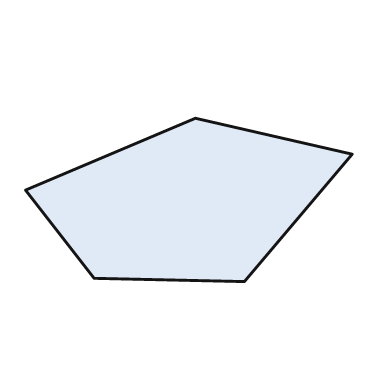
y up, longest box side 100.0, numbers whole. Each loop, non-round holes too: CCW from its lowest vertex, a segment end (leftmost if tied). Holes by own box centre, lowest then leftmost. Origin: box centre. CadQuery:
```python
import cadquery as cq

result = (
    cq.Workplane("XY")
    .moveTo(17.0, -25.0)
    .lineTo(50.0, 14.0)
    .lineTo(2.0, 25.0)
    .lineTo(-50.0, 3.0)
    .lineTo(-29.0, -24.0)
    .close()
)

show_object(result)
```